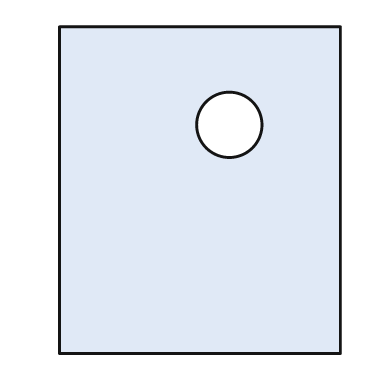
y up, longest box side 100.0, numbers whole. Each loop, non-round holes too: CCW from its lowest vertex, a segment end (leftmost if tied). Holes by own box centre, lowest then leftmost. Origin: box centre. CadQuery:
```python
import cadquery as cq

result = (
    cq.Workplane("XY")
    .moveTo(-43.0, -50.0)
    .lineTo(43.0, -50.0)
    .lineTo(43.0, 50.0)
    .lineTo(-43.0, 50.0)
    .close()
    .moveTo(9.0, 20.0)
    .circle(10.0)
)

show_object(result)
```